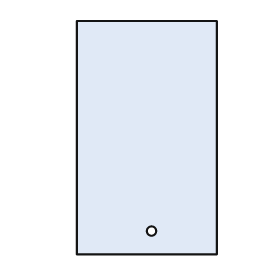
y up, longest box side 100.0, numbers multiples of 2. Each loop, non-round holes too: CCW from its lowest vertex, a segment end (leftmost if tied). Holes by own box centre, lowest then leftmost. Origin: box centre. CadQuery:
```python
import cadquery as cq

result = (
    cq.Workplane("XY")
    .moveTo(-30.0, -50.0)
    .lineTo(30.0, -50.0)
    .lineTo(30.0, 50.0)
    .lineTo(-30.0, 50.0)
    .close()
    .moveTo(2.0, -40.0)
    .circle(2.0)
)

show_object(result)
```